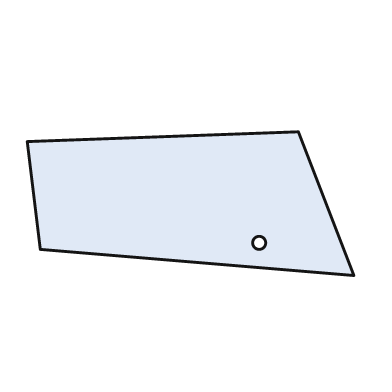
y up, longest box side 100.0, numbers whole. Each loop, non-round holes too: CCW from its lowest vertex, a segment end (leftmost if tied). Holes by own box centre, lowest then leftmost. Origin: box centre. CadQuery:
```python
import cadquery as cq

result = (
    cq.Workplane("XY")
    .moveTo(50.0, -22.0)
    .lineTo(33.0, 22.0)
    .lineTo(-50.0, 19.0)
    .lineTo(-46.0, -14.0)
    .close()
    .moveTo(21.0, -12.0)
    .circle(2.0)
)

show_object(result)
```